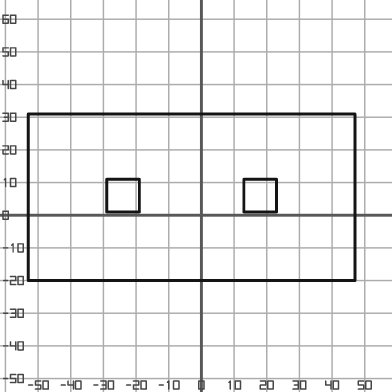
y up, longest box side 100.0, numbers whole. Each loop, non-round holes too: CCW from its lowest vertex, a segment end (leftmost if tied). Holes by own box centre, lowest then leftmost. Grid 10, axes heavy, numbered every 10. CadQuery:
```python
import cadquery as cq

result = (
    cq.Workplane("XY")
    .moveTo(-53.0, -20.0)
    .lineTo(47.0, -20.0)
    .lineTo(47.0, 31.0)
    .lineTo(-53.0, 31.0)
    .close()
    .moveTo(-29.0, 1.0)
    .lineTo(-19.0, 1.0)
    .lineTo(-19.0, 11.0)
    .lineTo(-29.0, 11.0)
    .close()
    .moveTo(13.0, 1.0)
    .lineTo(23.0, 1.0)
    .lineTo(23.0, 11.0)
    .lineTo(13.0, 11.0)
    .close()
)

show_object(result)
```